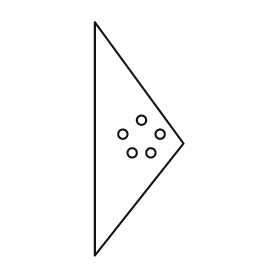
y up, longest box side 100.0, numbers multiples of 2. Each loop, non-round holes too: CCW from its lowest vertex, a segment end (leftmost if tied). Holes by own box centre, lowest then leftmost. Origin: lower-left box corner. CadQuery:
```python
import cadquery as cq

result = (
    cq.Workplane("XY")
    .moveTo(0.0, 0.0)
    .lineTo(38.0, 48.0)
    .lineTo(0.0, 100.0)
    .close()
    .moveTo(16.0, 44.0)
    .circle(2.0)
    .moveTo(24.0, 44.0)
    .circle(2.0)
    .moveTo(12.0, 52.0)
    .circle(2.0)
    .moveTo(28.0, 52.0)
    .circle(2.0)
    .moveTo(20.0, 58.0)
    .circle(2.0)
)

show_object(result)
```